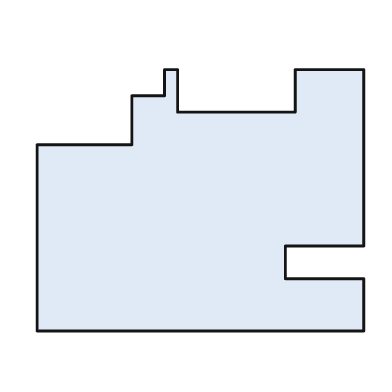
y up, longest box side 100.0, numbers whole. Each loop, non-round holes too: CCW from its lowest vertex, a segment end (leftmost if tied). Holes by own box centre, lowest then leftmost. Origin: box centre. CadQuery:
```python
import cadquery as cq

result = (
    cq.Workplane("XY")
    .moveTo(-50.0, -40.0)
    .lineTo(50.0, -40.0)
    .lineTo(50.0, -24.0)
    .lineTo(26.0, -24.0)
    .lineTo(26.0, -14.0)
    .lineTo(50.0, -14.0)
    .lineTo(50.0, 40.0)
    .lineTo(29.0, 40.0)
    .lineTo(29.0, 27.0)
    .lineTo(-7.0, 27.0)
    .lineTo(-7.0, 40.0)
    .lineTo(-11.0, 40.0)
    .lineTo(-11.0, 32.0)
    .lineTo(-21.0, 32.0)
    .lineTo(-21.0, 17.0)
    .lineTo(-50.0, 17.0)
    .close()
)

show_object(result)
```